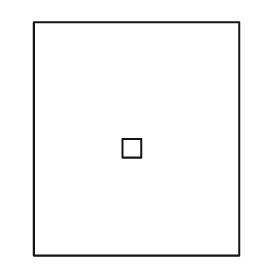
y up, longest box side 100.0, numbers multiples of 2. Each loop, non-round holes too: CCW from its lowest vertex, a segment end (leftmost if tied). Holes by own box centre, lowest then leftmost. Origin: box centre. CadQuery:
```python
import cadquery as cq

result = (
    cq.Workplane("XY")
    .moveTo(-44.0, -50.0)
    .lineTo(44.0, -50.0)
    .lineTo(44.0, 50.0)
    .lineTo(-44.0, 50.0)
    .close()
    .moveTo(-6.0, -8.0)
    .lineTo(2.0, -8.0)
    .lineTo(2.0, 0.0)
    .lineTo(-6.0, 0.0)
    .close()
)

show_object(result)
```